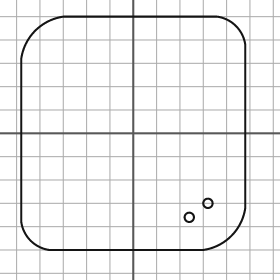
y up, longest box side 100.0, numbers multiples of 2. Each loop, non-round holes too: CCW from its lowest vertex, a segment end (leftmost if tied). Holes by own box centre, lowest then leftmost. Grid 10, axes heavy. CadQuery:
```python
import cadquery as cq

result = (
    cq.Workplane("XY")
    .moveTo(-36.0, -50.0)
    .lineTo(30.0, -50.0)
    .threePointArc((42.0, -44.0), (48.0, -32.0))
    .lineTo(48.0, 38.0)
    .threePointArc((44.0, 46.0), (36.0, 50.0))
    .lineTo(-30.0, 50.0)
    .threePointArc((-42.0, 44.0), (-48.0, 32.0))
    .lineTo(-48.0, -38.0)
    .threePointArc((-44.0, -46.0), (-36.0, -50.0))
    .close()
    .moveTo(24.0, -36.0)
    .circle(2.0)
    .moveTo(32.0, -30.0)
    .circle(2.0)
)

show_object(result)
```